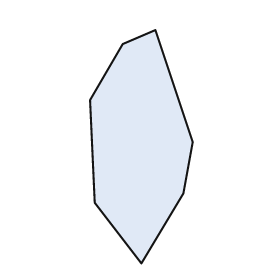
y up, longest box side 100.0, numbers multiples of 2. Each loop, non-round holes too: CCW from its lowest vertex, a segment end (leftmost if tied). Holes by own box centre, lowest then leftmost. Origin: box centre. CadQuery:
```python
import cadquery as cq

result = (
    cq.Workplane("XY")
    .moveTo(0.0, -50.0)
    .lineTo(18.0, -20.0)
    .lineTo(22.0, 2.0)
    .lineTo(6.0, 50.0)
    .lineTo(-8.0, 44.0)
    .lineTo(-22.0, 20.0)
    .lineTo(-20.0, -24.0)
    .close()
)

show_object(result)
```